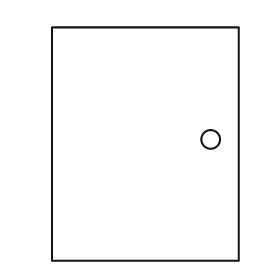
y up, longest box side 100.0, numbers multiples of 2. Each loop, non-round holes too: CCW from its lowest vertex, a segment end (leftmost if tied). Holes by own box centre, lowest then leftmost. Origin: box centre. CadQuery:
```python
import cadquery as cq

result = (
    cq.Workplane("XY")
    .moveTo(-40.0, -50.0)
    .lineTo(40.0, -50.0)
    .lineTo(40.0, 50.0)
    .lineTo(-40.0, 50.0)
    .close()
    .moveTo(28.0, 2.0)
    .circle(4.0)
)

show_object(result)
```